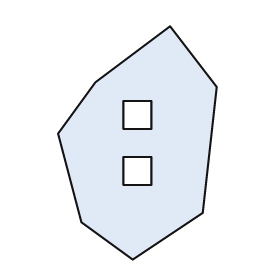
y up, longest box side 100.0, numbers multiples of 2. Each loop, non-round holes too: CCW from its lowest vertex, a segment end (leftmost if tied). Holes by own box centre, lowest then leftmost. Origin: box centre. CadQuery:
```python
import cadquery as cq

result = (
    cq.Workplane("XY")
    .moveTo(-2.0, -50.0)
    .lineTo(28.0, -30.0)
    .lineTo(34.0, 24.0)
    .lineTo(14.0, 50.0)
    .lineTo(-18.0, 26.0)
    .lineTo(-34.0, 4.0)
    .lineTo(-24.0, -34.0)
    .close()
    .moveTo(-6.0, -18.0)
    .lineTo(6.0, -18.0)
    .lineTo(6.0, -6.0)
    .lineTo(-6.0, -6.0)
    .close()
    .moveTo(-6.0, 6.0)
    .lineTo(6.0, 6.0)
    .lineTo(6.0, 18.0)
    .lineTo(-6.0, 18.0)
    .close()
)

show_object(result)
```